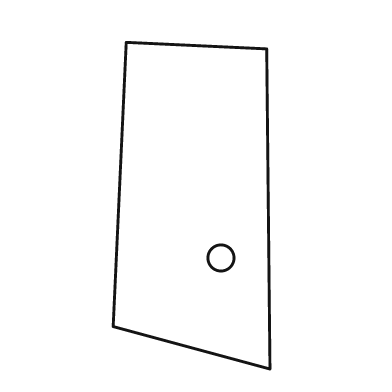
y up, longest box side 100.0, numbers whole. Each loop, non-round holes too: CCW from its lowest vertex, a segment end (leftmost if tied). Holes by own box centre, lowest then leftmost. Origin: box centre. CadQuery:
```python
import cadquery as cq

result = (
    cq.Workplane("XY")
    .moveTo(24.0, -50.0)
    .lineTo(23.0, 48.0)
    .lineTo(-20.0, 50.0)
    .lineTo(-24.0, -37.0)
    .close()
    .moveTo(9.0, -16.0)
    .circle(4.0)
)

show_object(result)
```